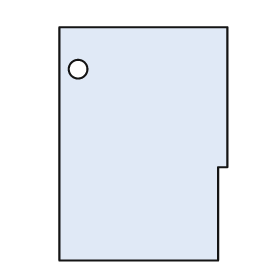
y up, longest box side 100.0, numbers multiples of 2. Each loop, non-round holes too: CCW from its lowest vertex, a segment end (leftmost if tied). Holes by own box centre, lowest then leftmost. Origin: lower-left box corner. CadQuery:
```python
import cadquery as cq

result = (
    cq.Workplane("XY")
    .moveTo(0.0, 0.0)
    .lineTo(68.0, 0.0)
    .lineTo(68.0, 40.0)
    .lineTo(72.0, 40.0)
    .lineTo(72.0, 100.0)
    .lineTo(0.0, 100.0)
    .close()
    .moveTo(8.0, 82.0)
    .circle(4.0)
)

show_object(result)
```